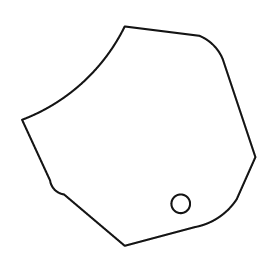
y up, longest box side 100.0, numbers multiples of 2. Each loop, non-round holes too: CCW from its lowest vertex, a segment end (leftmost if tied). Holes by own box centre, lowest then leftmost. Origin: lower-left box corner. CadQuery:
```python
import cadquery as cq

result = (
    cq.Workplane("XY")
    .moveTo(44.0, 0.0)
    .lineTo(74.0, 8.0)
    .threePointArc((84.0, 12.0), (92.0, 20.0))
    .lineTo(100.0, 38.0)
    .lineTo(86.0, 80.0)
    .threePointArc((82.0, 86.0), (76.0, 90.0))
    .lineTo(44.0, 94.0)
    .threePointArc((26.0, 70.0), (0.0, 54.0))
    .lineTo(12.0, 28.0)
    .threePointArc((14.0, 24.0), (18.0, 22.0))
    .close()
    .moveTo(68.0, 18.0)
    .circle(4.0)
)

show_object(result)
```